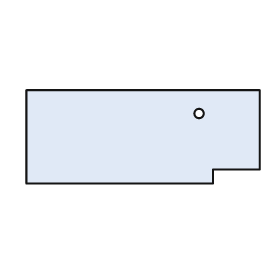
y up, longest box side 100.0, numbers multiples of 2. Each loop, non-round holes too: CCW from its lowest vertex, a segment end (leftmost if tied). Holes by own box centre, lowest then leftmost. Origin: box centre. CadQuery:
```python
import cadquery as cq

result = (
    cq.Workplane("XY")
    .moveTo(-50.0, -20.0)
    .lineTo(30.0, -20.0)
    .lineTo(30.0, -14.0)
    .lineTo(50.0, -14.0)
    .lineTo(50.0, 20.0)
    .lineTo(-50.0, 20.0)
    .close()
    .moveTo(24.0, 10.0)
    .circle(2.0)
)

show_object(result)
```